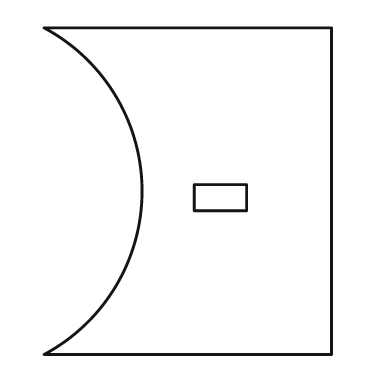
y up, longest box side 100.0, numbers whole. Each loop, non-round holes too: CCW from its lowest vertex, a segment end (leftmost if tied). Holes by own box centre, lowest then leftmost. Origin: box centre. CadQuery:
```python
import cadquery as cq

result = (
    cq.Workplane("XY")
    .moveTo(-44.0, -50.0)
    .lineTo(44.0, -50.0)
    .lineTo(44.0, 50.0)
    .lineTo(-44.0, 50.0)
    .threePointArc((-14.0, 0.0), (-44.0, -50.0))
    .close()
    .moveTo(2.0, -6.0)
    .lineTo(18.0, -6.0)
    .lineTo(18.0, 2.0)
    .lineTo(2.0, 2.0)
    .close()
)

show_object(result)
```